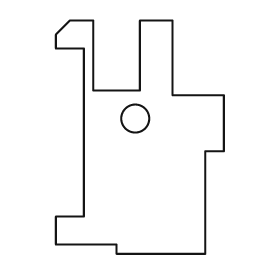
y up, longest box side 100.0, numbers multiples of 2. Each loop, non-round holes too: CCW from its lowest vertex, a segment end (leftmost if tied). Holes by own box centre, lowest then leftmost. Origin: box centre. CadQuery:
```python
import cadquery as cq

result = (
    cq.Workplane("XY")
    .moveTo(-10.0, -50.0)
    .lineTo(28.0, -50.0)
    .lineTo(28.0, -6.0)
    .lineTo(36.0, -6.0)
    .lineTo(36.0, 18.0)
    .lineTo(14.0, 18.0)
    .lineTo(14.0, 50.0)
    .lineTo(0.0, 50.0)
    .lineTo(0.0, 20.0)
    .lineTo(-20.0, 20.0)
    .lineTo(-20.0, 50.0)
    .lineTo(-30.0, 50.0)
    .lineTo(-36.0, 44.0)
    .lineTo(-36.0, 38.0)
    .lineTo(-24.0, 38.0)
    .lineTo(-24.0, -34.0)
    .lineTo(-36.0, -34.0)
    .lineTo(-36.0, -46.0)
    .lineTo(-10.0, -46.0)
    .close()
    .moveTo(-2.0, 8.0)
    .circle(6.0)
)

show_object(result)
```